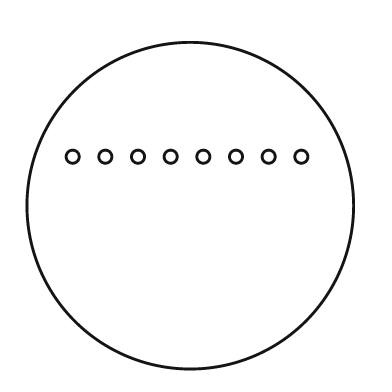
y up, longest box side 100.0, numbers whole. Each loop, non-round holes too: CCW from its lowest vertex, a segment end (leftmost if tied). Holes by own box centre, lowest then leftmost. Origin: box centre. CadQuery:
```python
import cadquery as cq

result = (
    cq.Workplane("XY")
    .moveTo(0.0, 0.0)
    .circle(50.0)
    .moveTo(-36.0, 15.0)
    .circle(2.0)
    .moveTo(-26.0, 15.0)
    .circle(2.0)
    .moveTo(-16.0, 15.0)
    .circle(2.0)
    .moveTo(-6.0, 15.0)
    .circle(2.0)
    .moveTo(4.0, 15.0)
    .circle(2.0)
    .moveTo(14.0, 15.0)
    .circle(2.0)
    .moveTo(24.0, 15.0)
    .circle(2.0)
    .moveTo(34.0, 15.0)
    .circle(2.0)
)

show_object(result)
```